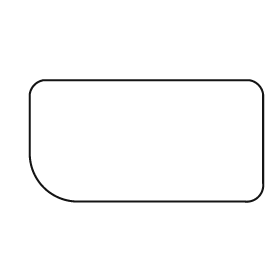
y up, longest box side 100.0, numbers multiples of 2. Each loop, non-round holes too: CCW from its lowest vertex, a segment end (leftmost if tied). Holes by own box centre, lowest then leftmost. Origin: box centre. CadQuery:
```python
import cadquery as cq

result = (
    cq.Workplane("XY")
    .moveTo(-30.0, -26.0)
    .lineTo(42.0, -26.0)
    .threePointArc((48.0, -24.0), (50.0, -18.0))
    .lineTo(50.0, 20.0)
    .threePointArc((48.0, 24.0), (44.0, 26.0))
    .lineTo(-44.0, 26.0)
    .threePointArc((-48.0, 24.0), (-50.0, 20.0))
    .lineTo(-50.0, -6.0)
    .threePointArc((-44.0, -20.0), (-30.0, -26.0))
    .close()
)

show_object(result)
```